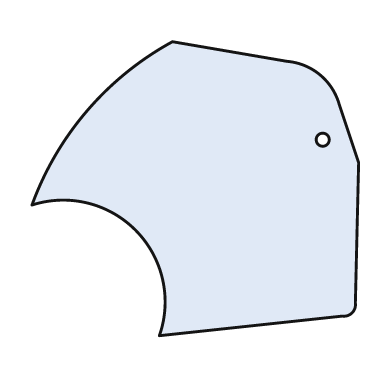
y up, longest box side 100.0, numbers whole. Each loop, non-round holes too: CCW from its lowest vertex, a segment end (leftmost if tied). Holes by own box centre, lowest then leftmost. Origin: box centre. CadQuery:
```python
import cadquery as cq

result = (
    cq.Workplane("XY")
    .moveTo(-11.0, -45.0)
    .lineTo(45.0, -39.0)
    .threePointArc((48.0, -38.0), (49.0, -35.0))
    .lineTo(50.0, 8.0)
    .lineTo(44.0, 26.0)
    .threePointArc((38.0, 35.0), (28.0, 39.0))
    .lineTo(-7.0, 45.0)
    .threePointArc((-33.0, 24.0), (-50.0, -5.0))
    .threePointArc((-18.0, -13.0), (-11.0, -45.0))
    .close()
    .moveTo(39.0, 15.0)
    .circle(2.0)
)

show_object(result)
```